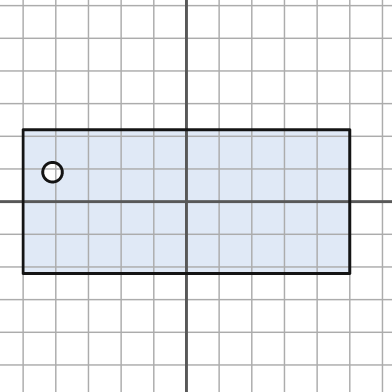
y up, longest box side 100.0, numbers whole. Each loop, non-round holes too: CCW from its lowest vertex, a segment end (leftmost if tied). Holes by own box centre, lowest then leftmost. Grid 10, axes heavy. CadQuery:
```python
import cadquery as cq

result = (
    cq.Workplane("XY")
    .moveTo(-50.0, -22.0)
    .lineTo(50.0, -22.0)
    .lineTo(50.0, 22.0)
    .lineTo(-50.0, 22.0)
    .close()
    .moveTo(-41.0, 9.0)
    .circle(3.0)
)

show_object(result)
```